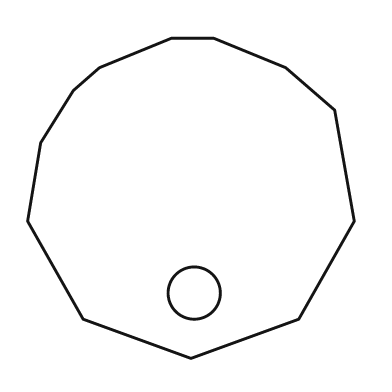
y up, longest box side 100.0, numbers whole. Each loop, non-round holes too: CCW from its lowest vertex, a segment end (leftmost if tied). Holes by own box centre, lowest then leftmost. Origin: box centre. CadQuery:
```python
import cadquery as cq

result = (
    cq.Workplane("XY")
    .moveTo(0.0, -49.0)
    .lineTo(33.0, -37.0)
    .lineTo(50.0, -7.0)
    .lineTo(44.0, 27.0)
    .lineTo(29.0, 40.0)
    .lineTo(7.0, 49.0)
    .lineTo(-6.0, 49.0)
    .lineTo(-28.0, 40.0)
    .lineTo(-36.0, 33.0)
    .lineTo(-46.0, 17.0)
    .lineTo(-50.0, -7.0)
    .lineTo(-33.0, -37.0)
    .close()
    .moveTo(1.0, -29.0)
    .circle(8.0)
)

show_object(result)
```